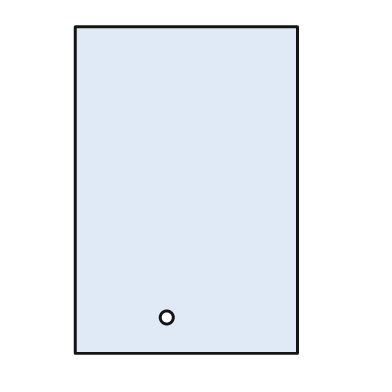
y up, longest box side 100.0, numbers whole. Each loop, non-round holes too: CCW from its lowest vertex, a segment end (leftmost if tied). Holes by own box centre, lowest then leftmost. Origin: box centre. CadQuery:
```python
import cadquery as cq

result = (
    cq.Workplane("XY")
    .moveTo(-34.0, -50.0)
    .lineTo(34.0, -50.0)
    .lineTo(34.0, 50.0)
    .lineTo(-34.0, 50.0)
    .close()
    .moveTo(-6.0, -39.0)
    .circle(2.0)
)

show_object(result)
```